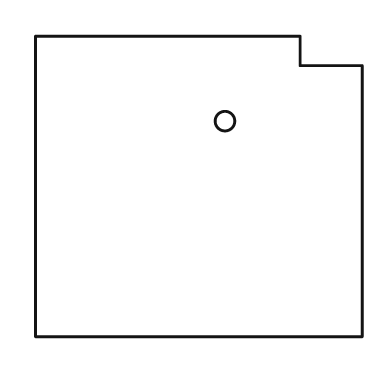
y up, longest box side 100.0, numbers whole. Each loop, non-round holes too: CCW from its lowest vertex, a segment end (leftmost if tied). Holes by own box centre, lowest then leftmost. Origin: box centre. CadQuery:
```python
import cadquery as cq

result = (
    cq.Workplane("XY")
    .moveTo(-50.0, -46.0)
    .lineTo(50.0, -46.0)
    .lineTo(50.0, 37.0)
    .lineTo(31.0, 37.0)
    .lineTo(31.0, 46.0)
    .lineTo(-50.0, 46.0)
    .close()
    .moveTo(8.0, 20.0)
    .circle(3.0)
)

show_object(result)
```